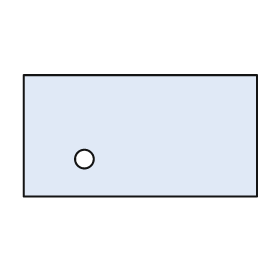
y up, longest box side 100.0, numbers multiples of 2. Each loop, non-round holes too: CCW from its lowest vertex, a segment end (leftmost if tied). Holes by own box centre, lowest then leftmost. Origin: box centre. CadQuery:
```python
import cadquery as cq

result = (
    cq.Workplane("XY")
    .moveTo(-50.0, -26.0)
    .lineTo(50.0, -26.0)
    .lineTo(50.0, 26.0)
    .lineTo(-50.0, 26.0)
    .close()
    .moveTo(-24.0, -10.0)
    .circle(4.0)
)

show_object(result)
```